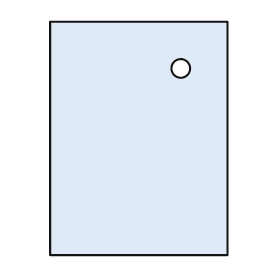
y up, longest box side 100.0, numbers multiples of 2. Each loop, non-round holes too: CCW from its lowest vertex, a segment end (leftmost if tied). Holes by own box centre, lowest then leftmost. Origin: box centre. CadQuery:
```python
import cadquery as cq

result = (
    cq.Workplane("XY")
    .moveTo(-38.0, -50.0)
    .lineTo(38.0, -50.0)
    .lineTo(38.0, 50.0)
    .lineTo(-38.0, 50.0)
    .close()
    .moveTo(18.0, 30.0)
    .circle(4.0)
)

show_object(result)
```